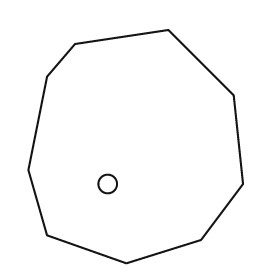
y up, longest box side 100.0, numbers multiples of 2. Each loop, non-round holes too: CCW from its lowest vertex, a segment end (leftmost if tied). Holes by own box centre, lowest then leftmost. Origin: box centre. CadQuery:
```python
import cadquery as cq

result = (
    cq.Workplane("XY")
    .moveTo(-4.0, -50.0)
    .lineTo(28.0, -40.0)
    .lineTo(46.0, -16.0)
    .lineTo(42.0, 22.0)
    .lineTo(14.0, 50.0)
    .lineTo(-26.0, 44.0)
    .lineTo(-38.0, 30.0)
    .lineTo(-46.0, -10.0)
    .lineTo(-38.0, -38.0)
    .close()
    .moveTo(-12.0, -16.0)
    .circle(4.0)
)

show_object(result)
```